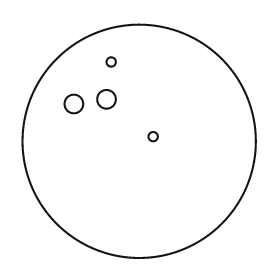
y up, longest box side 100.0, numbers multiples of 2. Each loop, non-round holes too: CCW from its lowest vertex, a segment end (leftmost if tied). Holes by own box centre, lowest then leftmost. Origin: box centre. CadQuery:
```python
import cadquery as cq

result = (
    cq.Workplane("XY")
    .moveTo(0.0, 0.0)
    .circle(50.0)
    .moveTo(6.0, 2.0)
    .circle(2.0)
    .moveTo(-28.0, 16.0)
    .circle(4.0)
    .moveTo(-14.0, 18.0)
    .circle(4.0)
    .moveTo(-12.0, 34.0)
    .circle(2.0)
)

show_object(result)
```